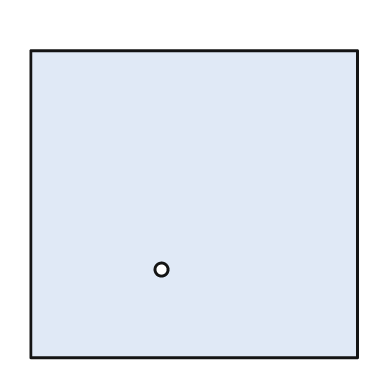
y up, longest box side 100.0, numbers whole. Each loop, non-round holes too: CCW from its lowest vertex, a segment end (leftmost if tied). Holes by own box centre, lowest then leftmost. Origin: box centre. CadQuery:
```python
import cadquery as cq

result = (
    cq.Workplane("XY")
    .moveTo(-50.0, -47.0)
    .lineTo(50.0, -47.0)
    .lineTo(50.0, 47.0)
    .lineTo(-50.0, 47.0)
    .close()
    .moveTo(-10.0, -20.0)
    .circle(2.0)
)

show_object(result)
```